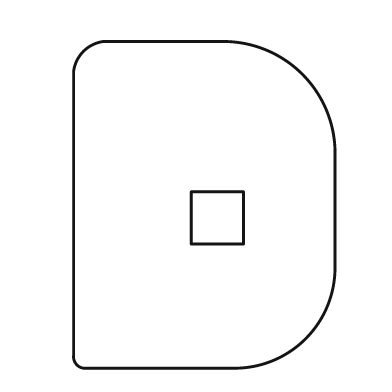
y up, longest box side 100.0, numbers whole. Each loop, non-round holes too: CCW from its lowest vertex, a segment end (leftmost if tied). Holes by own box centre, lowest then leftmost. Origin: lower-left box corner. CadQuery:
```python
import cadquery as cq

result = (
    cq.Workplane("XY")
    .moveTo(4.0, 0.0)
    .lineTo(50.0, 0.0)
    .threePointArc((71.0, 9.0), (80.0, 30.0))
    .lineTo(80.0, 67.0)
    .threePointArc((70.0, 90.0), (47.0, 100.0))
    .lineTo(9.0, 100.0)
    .threePointArc((3.0, 97.0), (0.0, 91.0))
    .lineTo(0.0, 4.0)
    .threePointArc((1.0, 1.0), (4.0, 0.0))
    .close()
    .moveTo(36.0, 38.0)
    .lineTo(52.0, 38.0)
    .lineTo(52.0, 54.0)
    .lineTo(36.0, 54.0)
    .close()
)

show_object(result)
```